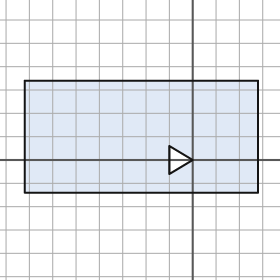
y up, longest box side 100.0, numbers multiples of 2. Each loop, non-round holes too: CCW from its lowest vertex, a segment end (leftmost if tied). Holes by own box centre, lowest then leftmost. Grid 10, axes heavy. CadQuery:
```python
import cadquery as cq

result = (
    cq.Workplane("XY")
    .moveTo(-72.0, -14.0)
    .lineTo(28.0, -14.0)
    .lineTo(28.0, 34.0)
    .lineTo(-72.0, 34.0)
    .close()
    .moveTo(-10.0, -6.0)
    .lineTo(0.0, 0.0)
    .lineTo(-10.0, 6.0)
    .close()
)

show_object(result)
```